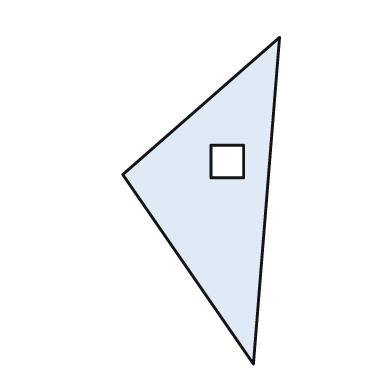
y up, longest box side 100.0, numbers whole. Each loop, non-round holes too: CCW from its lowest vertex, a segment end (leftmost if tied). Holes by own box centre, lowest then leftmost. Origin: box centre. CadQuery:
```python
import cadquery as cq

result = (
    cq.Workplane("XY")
    .moveTo(16.0, -50.0)
    .lineTo(24.0, 50.0)
    .lineTo(-24.0, 8.0)
    .close()
    .moveTo(3.0, 7.0)
    .lineTo(13.0, 7.0)
    .lineTo(13.0, 17.0)
    .lineTo(3.0, 17.0)
    .close()
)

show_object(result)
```